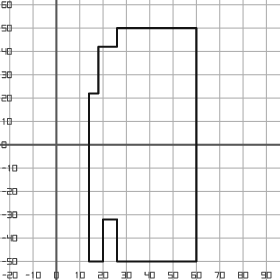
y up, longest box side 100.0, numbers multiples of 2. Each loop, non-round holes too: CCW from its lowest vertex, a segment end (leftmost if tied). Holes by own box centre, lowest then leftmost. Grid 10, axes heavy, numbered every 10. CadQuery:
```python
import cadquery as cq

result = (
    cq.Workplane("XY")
    .moveTo(14.0, -50.0)
    .lineTo(20.0, -50.0)
    .lineTo(20.0, -32.0)
    .lineTo(26.0, -32.0)
    .lineTo(26.0, -50.0)
    .lineTo(60.0, -50.0)
    .lineTo(60.0, 50.0)
    .lineTo(26.0, 50.0)
    .lineTo(26.0, 42.0)
    .lineTo(18.0, 42.0)
    .lineTo(18.0, 22.0)
    .lineTo(14.0, 22.0)
    .close()
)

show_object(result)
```